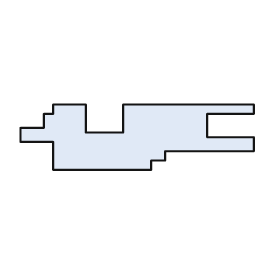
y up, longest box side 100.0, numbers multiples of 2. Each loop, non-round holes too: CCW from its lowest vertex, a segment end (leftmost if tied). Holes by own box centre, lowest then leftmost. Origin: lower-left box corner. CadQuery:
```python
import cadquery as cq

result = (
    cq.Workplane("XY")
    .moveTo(14.0, 0.0)
    .lineTo(56.0, 0.0)
    .lineTo(56.0, 4.0)
    .lineTo(62.0, 4.0)
    .lineTo(62.0, 8.0)
    .lineTo(100.0, 8.0)
    .lineTo(100.0, 14.0)
    .lineTo(80.0, 14.0)
    .lineTo(80.0, 24.0)
    .lineTo(100.0, 24.0)
    .lineTo(100.0, 28.0)
    .lineTo(44.0, 28.0)
    .lineTo(44.0, 16.0)
    .lineTo(28.0, 16.0)
    .lineTo(28.0, 28.0)
    .lineTo(14.0, 28.0)
    .lineTo(14.0, 24.0)
    .lineTo(10.0, 24.0)
    .lineTo(10.0, 18.0)
    .lineTo(0.0, 18.0)
    .lineTo(0.0, 12.0)
    .lineTo(14.0, 12.0)
    .close()
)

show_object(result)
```